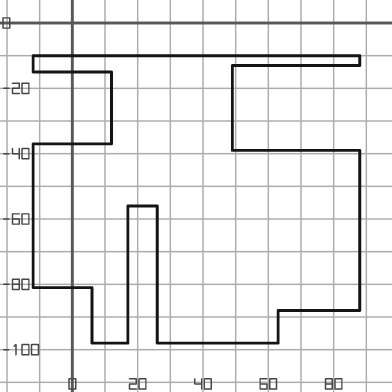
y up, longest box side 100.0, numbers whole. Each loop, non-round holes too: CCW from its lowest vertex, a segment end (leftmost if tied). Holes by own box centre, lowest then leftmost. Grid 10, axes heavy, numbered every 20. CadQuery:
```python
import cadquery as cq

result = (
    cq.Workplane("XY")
    .moveTo(6.0, -98.0)
    .lineTo(17.0, -98.0)
    .lineTo(17.0, -56.0)
    .lineTo(26.0, -56.0)
    .lineTo(26.0, -98.0)
    .lineTo(63.0, -98.0)
    .lineTo(63.0, -88.0)
    .lineTo(88.0, -88.0)
    .lineTo(88.0, -39.0)
    .lineTo(49.0, -39.0)
    .lineTo(49.0, -13.0)
    .lineTo(88.0, -13.0)
    .lineTo(88.0, -10.0)
    .lineTo(-12.0, -10.0)
    .lineTo(-12.0, -15.0)
    .lineTo(12.0, -15.0)
    .lineTo(12.0, -37.0)
    .lineTo(-12.0, -37.0)
    .lineTo(-12.0, -81.0)
    .lineTo(6.0, -81.0)
    .close()
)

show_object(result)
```